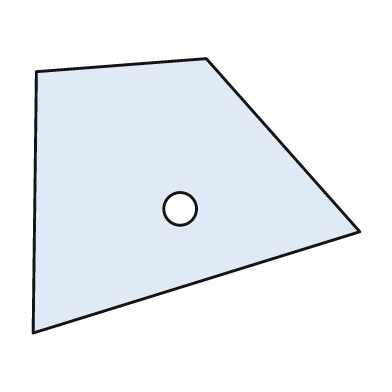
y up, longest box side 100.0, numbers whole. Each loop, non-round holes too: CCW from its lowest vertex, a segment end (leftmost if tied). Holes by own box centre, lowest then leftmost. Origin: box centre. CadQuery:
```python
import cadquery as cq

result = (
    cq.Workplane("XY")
    .moveTo(-50.0, -42.0)
    .lineTo(50.0, -11.0)
    .lineTo(3.0, 42.0)
    .lineTo(-49.0, 38.0)
    .close()
    .moveTo(-5.0, -4.0)
    .circle(5.0)
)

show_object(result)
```